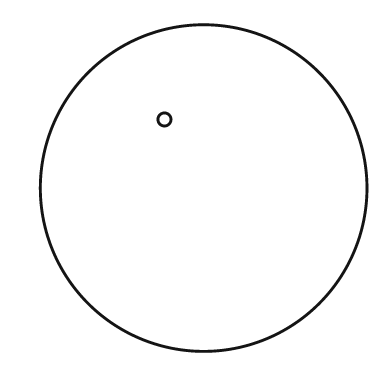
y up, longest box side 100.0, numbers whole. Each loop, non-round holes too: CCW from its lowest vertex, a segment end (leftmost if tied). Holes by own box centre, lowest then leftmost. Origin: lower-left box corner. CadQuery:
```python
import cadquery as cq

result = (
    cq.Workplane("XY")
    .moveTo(50.0, 50.0)
    .circle(50.0)
    .moveTo(38.0, 71.0)
    .circle(2.0)
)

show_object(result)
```